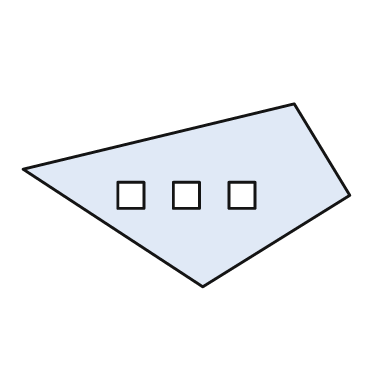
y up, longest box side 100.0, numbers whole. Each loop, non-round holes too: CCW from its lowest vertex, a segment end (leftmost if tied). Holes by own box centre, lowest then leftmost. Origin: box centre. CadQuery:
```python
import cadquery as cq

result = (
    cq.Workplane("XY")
    .moveTo(5.0, -28.0)
    .lineTo(50.0, 0.0)
    .lineTo(33.0, 28.0)
    .lineTo(-50.0, 8.0)
    .close()
    .moveTo(-21.0, -4.0)
    .lineTo(-13.0, -4.0)
    .lineTo(-13.0, 4.0)
    .lineTo(-21.0, 4.0)
    .close()
    .moveTo(-4.0, -4.0)
    .lineTo(4.0, -4.0)
    .lineTo(4.0, 4.0)
    .lineTo(-4.0, 4.0)
    .close()
    .moveTo(13.0, -4.0)
    .lineTo(21.0, -4.0)
    .lineTo(21.0, 4.0)
    .lineTo(13.0, 4.0)
    .close()
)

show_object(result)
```